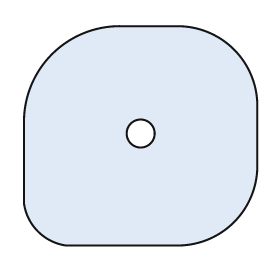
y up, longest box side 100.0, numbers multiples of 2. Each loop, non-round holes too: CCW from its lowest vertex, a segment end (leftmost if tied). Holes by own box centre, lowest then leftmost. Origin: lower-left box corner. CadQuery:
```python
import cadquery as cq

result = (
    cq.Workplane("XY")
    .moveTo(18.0, 0.0)
    .lineTo(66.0, 0.0)
    .threePointArc((90.0, 10.0), (100.0, 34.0))
    .lineTo(100.0, 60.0)
    .threePointArc((90.0, 84.0), (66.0, 94.0))
    .lineTo(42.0, 94.0)
    .threePointArc((12.0, 82.0), (0.0, 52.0))
    .lineTo(0.0, 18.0)
    .threePointArc((6.0, 6.0), (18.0, 0.0))
    .close()
    .moveTo(50.0, 48.0)
    .circle(6.0)
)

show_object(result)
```